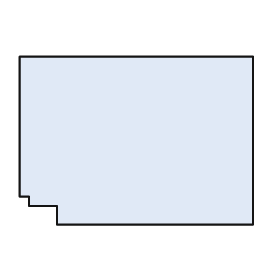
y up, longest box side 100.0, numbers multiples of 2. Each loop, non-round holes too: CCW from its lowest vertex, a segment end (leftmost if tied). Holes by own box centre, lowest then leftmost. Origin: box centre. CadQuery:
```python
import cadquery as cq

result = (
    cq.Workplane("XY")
    .moveTo(-34.0, -36.0)
    .lineTo(50.0, -36.0)
    .lineTo(50.0, 36.0)
    .lineTo(-50.0, 36.0)
    .lineTo(-50.0, -24.0)
    .lineTo(-46.0, -24.0)
    .lineTo(-46.0, -28.0)
    .lineTo(-34.0, -28.0)
    .close()
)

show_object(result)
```